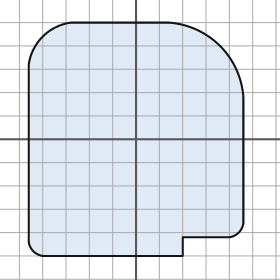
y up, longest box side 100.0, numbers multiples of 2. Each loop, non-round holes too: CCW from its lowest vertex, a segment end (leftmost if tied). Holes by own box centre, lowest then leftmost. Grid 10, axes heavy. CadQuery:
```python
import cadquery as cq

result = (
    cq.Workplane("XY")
    .moveTo(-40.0, -50.0)
    .lineTo(20.0, -50.0)
    .lineTo(20.0, -42.0)
    .lineTo(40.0, -42.0)
    .threePointArc((44.0, -40.0), (46.0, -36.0))
    .lineTo(46.0, 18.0)
    .threePointArc((36.0, 40.0), (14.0, 50.0))
    .lineTo(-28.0, 50.0)
    .threePointArc((-40.0, 44.0), (-46.0, 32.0))
    .lineTo(-46.0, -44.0)
    .threePointArc((-44.0, -48.0), (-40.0, -50.0))
    .close()
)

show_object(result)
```